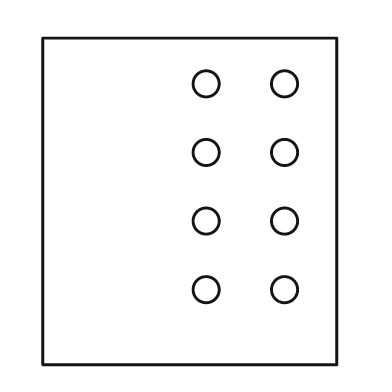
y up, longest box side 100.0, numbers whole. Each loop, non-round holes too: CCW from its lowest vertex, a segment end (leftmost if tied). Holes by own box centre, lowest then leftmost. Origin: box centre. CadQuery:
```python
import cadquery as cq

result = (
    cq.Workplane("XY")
    .moveTo(-45.0, -50.0)
    .lineTo(45.0, -50.0)
    .lineTo(45.0, 50.0)
    .lineTo(-45.0, 50.0)
    .close()
    .moveTo(5.0, -27.0)
    .circle(4.0)
    .moveTo(29.0, -27.0)
    .circle(4.0)
    .moveTo(5.0, -6.0)
    .circle(4.0)
    .moveTo(29.0, -6.0)
    .circle(4.0)
    .moveTo(5.0, 15.0)
    .circle(4.0)
    .moveTo(29.0, 15.0)
    .circle(4.0)
    .moveTo(5.0, 36.0)
    .circle(4.0)
    .moveTo(29.0, 36.0)
    .circle(4.0)
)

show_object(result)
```